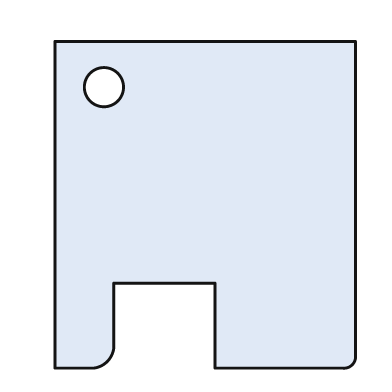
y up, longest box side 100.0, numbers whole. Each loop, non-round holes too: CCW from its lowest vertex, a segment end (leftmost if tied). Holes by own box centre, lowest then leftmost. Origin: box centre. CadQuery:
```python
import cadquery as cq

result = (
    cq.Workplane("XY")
    .moveTo(-46.0, -50.0)
    .lineTo(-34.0, -50.0)
    .threePointArc((-30.0, -48.0), (-28.0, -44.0))
    .lineTo(-28.0, -24.0)
    .lineTo(3.0, -24.0)
    .lineTo(3.0, -50.0)
    .lineTo(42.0, -50.0)
    .threePointArc((45.0, -49.0), (46.0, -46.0))
    .lineTo(46.0, 50.0)
    .lineTo(-46.0, 50.0)
    .close()
    .moveTo(-31.0, 36.0)
    .circle(6.0)
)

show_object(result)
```